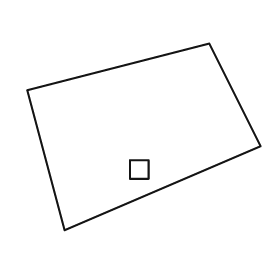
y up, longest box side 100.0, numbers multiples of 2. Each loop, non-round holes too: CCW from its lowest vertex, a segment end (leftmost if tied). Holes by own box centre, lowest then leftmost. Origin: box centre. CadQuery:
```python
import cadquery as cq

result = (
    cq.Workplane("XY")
    .moveTo(-34.0, -40.0)
    .lineTo(50.0, -4.0)
    .lineTo(28.0, 40.0)
    .lineTo(-50.0, 20.0)
    .close()
    .moveTo(-6.0, -18.0)
    .lineTo(2.0, -18.0)
    .lineTo(2.0, -10.0)
    .lineTo(-6.0, -10.0)
    .close()
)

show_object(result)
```